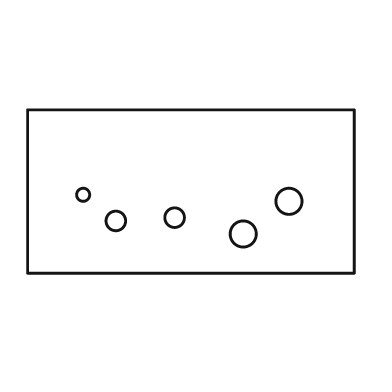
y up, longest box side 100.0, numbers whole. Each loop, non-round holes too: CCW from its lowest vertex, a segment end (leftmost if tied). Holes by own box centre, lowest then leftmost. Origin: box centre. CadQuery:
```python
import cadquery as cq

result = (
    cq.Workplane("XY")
    .moveTo(-50.0, -25.0)
    .lineTo(50.0, -25.0)
    .lineTo(50.0, 25.0)
    .lineTo(-50.0, 25.0)
    .close()
    .moveTo(16.0, -13.0)
    .circle(4.0)
    .moveTo(-23.0, -9.0)
    .circle(3.0)
    .moveTo(-5.0, -8.0)
    .circle(3.0)
    .moveTo(30.0, -3.0)
    .circle(4.0)
    .moveTo(-33.0, -1.0)
    .circle(2.0)
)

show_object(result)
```